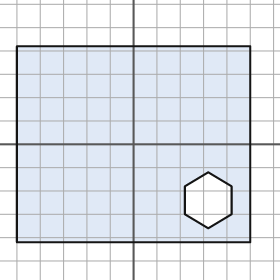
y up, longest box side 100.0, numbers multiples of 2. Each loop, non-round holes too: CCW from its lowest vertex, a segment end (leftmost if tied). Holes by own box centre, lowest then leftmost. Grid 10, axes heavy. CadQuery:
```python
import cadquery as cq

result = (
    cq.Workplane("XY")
    .moveTo(-50.0, -42.0)
    .lineTo(50.0, -42.0)
    .lineTo(50.0, 42.0)
    .lineTo(-50.0, 42.0)
    .close()
    .moveTo(32.0, -36.0)
    .lineTo(42.0, -30.0)
    .lineTo(42.0, -18.0)
    .lineTo(32.0, -12.0)
    .lineTo(22.0, -18.0)
    .lineTo(22.0, -30.0)
    .close()
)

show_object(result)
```